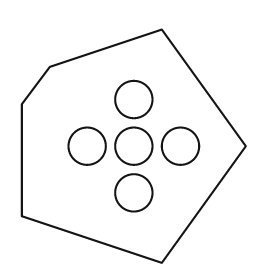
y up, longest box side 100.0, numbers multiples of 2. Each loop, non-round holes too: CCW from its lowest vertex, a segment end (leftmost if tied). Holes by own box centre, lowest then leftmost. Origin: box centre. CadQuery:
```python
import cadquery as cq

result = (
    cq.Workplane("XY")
    .moveTo(12.0, -50.0)
    .lineTo(48.0, 0.0)
    .lineTo(12.0, 50.0)
    .lineTo(-36.0, 34.0)
    .lineTo(-48.0, 18.0)
    .lineTo(-48.0, -30.0)
    .close()
    .moveTo(0.0, -20.0)
    .circle(8.0)
    .moveTo(-20.0, 0.0)
    .circle(8.0)
    .moveTo(0.0, 0.0)
    .circle(8.0)
    .moveTo(20.0, 0.0)
    .circle(8.0)
    .moveTo(0.0, 20.0)
    .circle(8.0)
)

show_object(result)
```